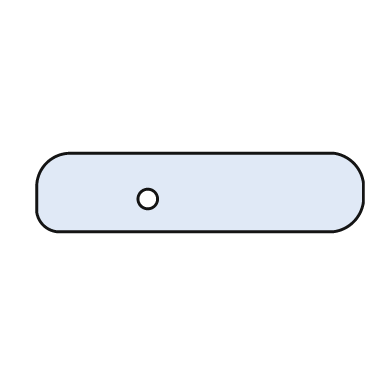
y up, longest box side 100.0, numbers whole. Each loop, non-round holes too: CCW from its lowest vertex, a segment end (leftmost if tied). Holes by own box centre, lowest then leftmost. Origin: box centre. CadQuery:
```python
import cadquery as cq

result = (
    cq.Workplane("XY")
    .moveTo(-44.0, -12.0)
    .lineTo(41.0, -12.0)
    .threePointArc((47.0, -9.0), (50.0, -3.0))
    .lineTo(50.0, 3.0)
    .threePointArc((47.0, 9.0), (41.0, 12.0))
    .lineTo(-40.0, 12.0)
    .threePointArc((-47.0, 9.0), (-50.0, 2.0))
    .lineTo(-50.0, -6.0)
    .threePointArc((-48.0, -10.0), (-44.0, -12.0))
    .close()
    .moveTo(-16.0, -2.0)
    .circle(3.0)
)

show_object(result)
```